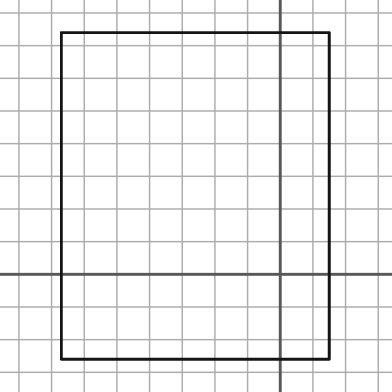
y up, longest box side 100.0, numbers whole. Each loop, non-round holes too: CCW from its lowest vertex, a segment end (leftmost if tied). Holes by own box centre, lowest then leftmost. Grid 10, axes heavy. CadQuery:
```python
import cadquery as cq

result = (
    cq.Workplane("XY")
    .moveTo(-67.0, -26.0)
    .lineTo(15.0, -26.0)
    .lineTo(15.0, 74.0)
    .lineTo(-67.0, 74.0)
    .close()
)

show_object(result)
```